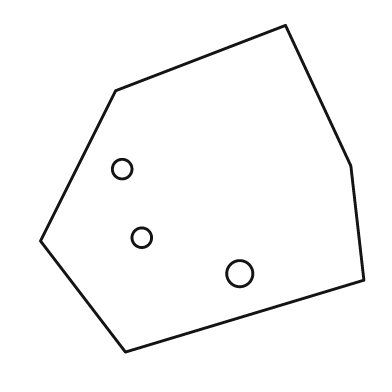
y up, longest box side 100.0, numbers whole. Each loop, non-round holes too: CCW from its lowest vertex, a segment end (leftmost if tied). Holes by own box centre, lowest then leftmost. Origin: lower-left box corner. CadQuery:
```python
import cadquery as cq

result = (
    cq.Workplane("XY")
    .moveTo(26.0, 0.0)
    .lineTo(99.0, 22.0)
    .lineTo(95.0, 57.0)
    .lineTo(75.0, 100.0)
    .lineTo(23.0, 80.0)
    .lineTo(0.0, 34.0)
    .close()
    .moveTo(61.0, 24.0)
    .circle(4.0)
    .moveTo(31.0, 35.0)
    .circle(3.0)
    .moveTo(25.0, 56.0)
    .circle(3.0)
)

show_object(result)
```